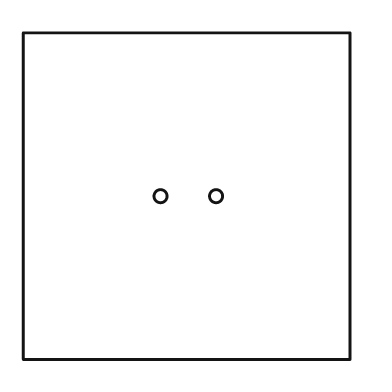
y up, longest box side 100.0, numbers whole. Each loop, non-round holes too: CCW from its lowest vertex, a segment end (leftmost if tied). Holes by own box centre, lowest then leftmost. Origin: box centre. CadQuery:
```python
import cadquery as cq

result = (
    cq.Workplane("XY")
    .moveTo(-50.0, -50.0)
    .lineTo(50.0, -50.0)
    .lineTo(50.0, 50.0)
    .lineTo(-50.0, 50.0)
    .close()
    .moveTo(-8.0, 0.0)
    .circle(2.0)
    .moveTo(9.0, 0.0)
    .circle(2.0)
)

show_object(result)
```